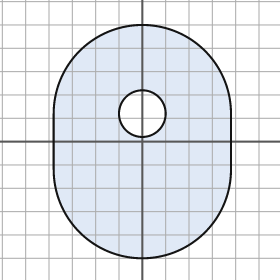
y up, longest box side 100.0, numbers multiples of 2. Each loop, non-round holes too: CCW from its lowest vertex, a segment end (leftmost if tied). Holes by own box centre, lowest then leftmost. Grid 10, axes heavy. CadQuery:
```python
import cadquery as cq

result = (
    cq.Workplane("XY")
    .moveTo(-38.0, -12.0)
    .threePointArc((0.0, -50.0), (38.0, -12.0))
    .lineTo(38.0, 12.0)
    .threePointArc((0.0, 50.0), (-38.0, 12.0))
    .close()
    .moveTo(0.0, 12.0)
    .circle(10.0)
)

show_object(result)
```